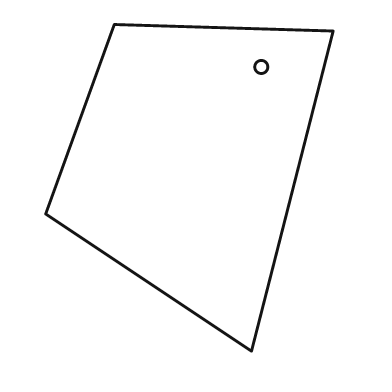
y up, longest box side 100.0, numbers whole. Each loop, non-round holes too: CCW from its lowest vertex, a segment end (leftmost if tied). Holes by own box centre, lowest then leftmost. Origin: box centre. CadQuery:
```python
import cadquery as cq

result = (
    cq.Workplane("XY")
    .moveTo(19.0, -50.0)
    .lineTo(44.0, 48.0)
    .lineTo(-23.0, 50.0)
    .lineTo(-44.0, -8.0)
    .close()
    .moveTo(22.0, 37.0)
    .circle(2.0)
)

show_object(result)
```